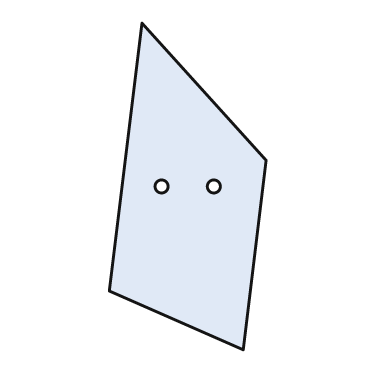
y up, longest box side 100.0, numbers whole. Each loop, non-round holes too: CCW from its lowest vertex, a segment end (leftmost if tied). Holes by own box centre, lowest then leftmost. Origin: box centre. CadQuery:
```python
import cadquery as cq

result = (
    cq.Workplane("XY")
    .moveTo(17.0, -50.0)
    .lineTo(24.0, 8.0)
    .lineTo(-14.0, 50.0)
    .lineTo(-24.0, -32.0)
    .close()
    .moveTo(-8.0, 0.0)
    .circle(2.0)
    .moveTo(8.0, 0.0)
    .circle(2.0)
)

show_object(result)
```